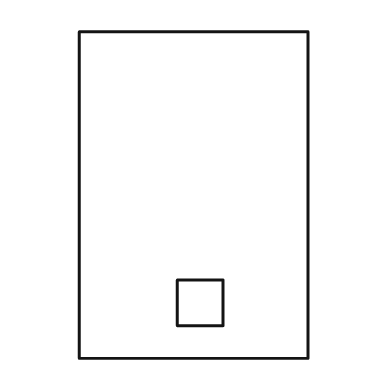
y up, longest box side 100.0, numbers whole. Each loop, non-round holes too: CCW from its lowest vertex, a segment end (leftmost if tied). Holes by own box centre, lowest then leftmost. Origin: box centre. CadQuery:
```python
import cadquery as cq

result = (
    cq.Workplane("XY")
    .moveTo(-35.0, -50.0)
    .lineTo(35.0, -50.0)
    .lineTo(35.0, 50.0)
    .lineTo(-35.0, 50.0)
    .close()
    .moveTo(-5.0, -40.0)
    .lineTo(9.0, -40.0)
    .lineTo(9.0, -26.0)
    .lineTo(-5.0, -26.0)
    .close()
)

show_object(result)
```